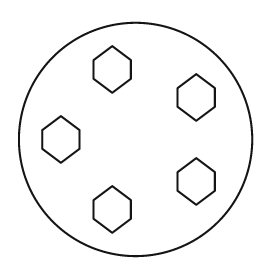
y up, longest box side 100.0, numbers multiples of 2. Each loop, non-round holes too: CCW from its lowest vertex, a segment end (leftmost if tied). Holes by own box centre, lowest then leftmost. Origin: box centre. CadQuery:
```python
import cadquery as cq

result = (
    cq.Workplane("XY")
    .moveTo(0.0, 0.0)
    .circle(50.0)
    .moveTo(-10.0, -40.0)
    .lineTo(-2.0, -34.0)
    .lineTo(-2.0, -26.0)
    .lineTo(-10.0, -20.0)
    .lineTo(-18.0, -26.0)
    .lineTo(-18.0, -34.0)
    .close()
    .moveTo(26.0, -28.0)
    .lineTo(34.0, -22.0)
    .lineTo(34.0, -14.0)
    .lineTo(26.0, -8.0)
    .lineTo(18.0, -14.0)
    .lineTo(18.0, -22.0)
    .close()
    .moveTo(-32.0, -10.0)
    .lineTo(-24.0, -4.0)
    .lineTo(-24.0, 4.0)
    .lineTo(-32.0, 10.0)
    .lineTo(-40.0, 4.0)
    .lineTo(-40.0, -4.0)
    .close()
    .moveTo(26.0, 8.0)
    .lineTo(34.0, 14.0)
    .lineTo(34.0, 22.0)
    .lineTo(26.0, 28.0)
    .lineTo(18.0, 22.0)
    .lineTo(18.0, 14.0)
    .close()
    .moveTo(-10.0, 20.0)
    .lineTo(-2.0, 26.0)
    .lineTo(-2.0, 34.0)
    .lineTo(-10.0, 40.0)
    .lineTo(-18.0, 34.0)
    .lineTo(-18.0, 26.0)
    .close()
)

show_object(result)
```